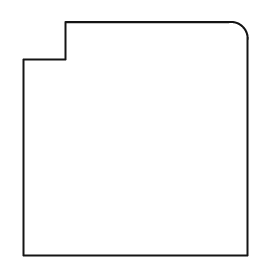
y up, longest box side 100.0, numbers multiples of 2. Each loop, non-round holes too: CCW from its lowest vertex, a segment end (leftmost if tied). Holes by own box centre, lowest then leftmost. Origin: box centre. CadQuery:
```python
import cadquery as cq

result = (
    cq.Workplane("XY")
    .moveTo(-48.0, -50.0)
    .lineTo(48.0, -50.0)
    .lineTo(48.0, 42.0)
    .threePointArc((46.0, 48.0), (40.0, 50.0))
    .lineTo(-30.0, 50.0)
    .lineTo(-30.0, 34.0)
    .lineTo(-48.0, 34.0)
    .close()
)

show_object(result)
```